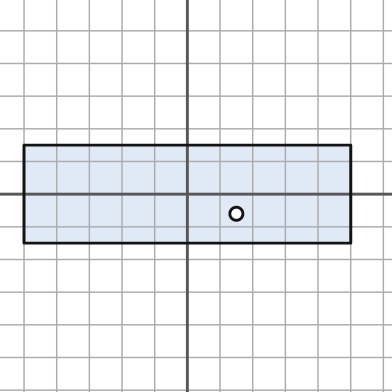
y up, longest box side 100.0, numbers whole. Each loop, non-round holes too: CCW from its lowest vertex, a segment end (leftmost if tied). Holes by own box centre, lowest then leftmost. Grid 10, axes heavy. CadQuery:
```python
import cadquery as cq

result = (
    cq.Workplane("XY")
    .moveTo(-50.0, -15.0)
    .lineTo(50.0, -15.0)
    .lineTo(50.0, 15.0)
    .lineTo(-50.0, 15.0)
    .close()
    .moveTo(15.0, -6.0)
    .circle(2.0)
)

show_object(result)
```